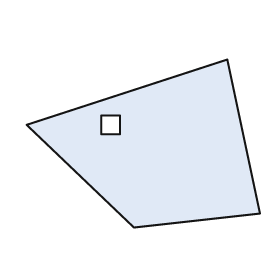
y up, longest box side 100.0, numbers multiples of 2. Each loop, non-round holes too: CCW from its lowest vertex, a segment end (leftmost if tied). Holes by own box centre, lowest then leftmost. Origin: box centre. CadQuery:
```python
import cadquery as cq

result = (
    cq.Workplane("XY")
    .moveTo(-4.0, -36.0)
    .lineTo(50.0, -30.0)
    .lineTo(36.0, 36.0)
    .lineTo(-50.0, 8.0)
    .close()
    .moveTo(-18.0, 4.0)
    .lineTo(-10.0, 4.0)
    .lineTo(-10.0, 12.0)
    .lineTo(-18.0, 12.0)
    .close()
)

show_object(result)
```